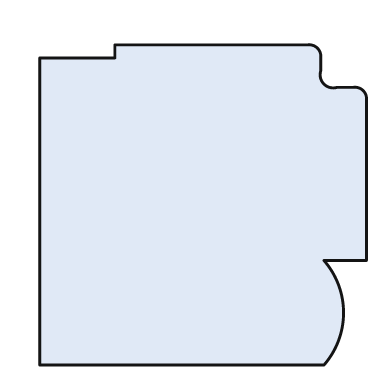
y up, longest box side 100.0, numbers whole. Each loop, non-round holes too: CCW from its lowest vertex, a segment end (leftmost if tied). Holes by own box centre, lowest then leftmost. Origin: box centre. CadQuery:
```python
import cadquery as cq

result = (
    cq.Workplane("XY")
    .moveTo(-50.0, -49.0)
    .lineTo(37.0, -49.0)
    .threePointArc((43.0, -33.0), (37.0, -17.0))
    .lineTo(50.0, -17.0)
    .lineTo(50.0, 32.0)
    .threePointArc((49.0, 35.0), (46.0, 36.0))
    .lineTo(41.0, 36.0)
    .threePointArc((37.0, 37.0), (36.0, 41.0))
    .lineTo(36.0, 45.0)
    .threePointArc((35.0, 48.0), (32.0, 49.0))
    .lineTo(-27.0, 49.0)
    .lineTo(-27.0, 45.0)
    .lineTo(-50.0, 45.0)
    .close()
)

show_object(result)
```